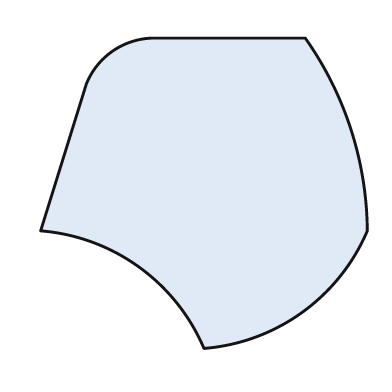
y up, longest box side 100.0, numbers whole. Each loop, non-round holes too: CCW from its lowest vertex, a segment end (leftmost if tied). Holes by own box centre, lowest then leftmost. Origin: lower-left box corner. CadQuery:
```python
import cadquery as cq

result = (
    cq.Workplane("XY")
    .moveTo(50.0, 0.0)
    .threePointArc((80.0, 11.0), (100.0, 36.0))
    .threePointArc((95.0, 67.0), (81.0, 95.0))
    .lineTo(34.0, 95.0)
    .threePointArc((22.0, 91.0), (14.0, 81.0))
    .lineTo(0.0, 36.0)
    .threePointArc((30.0, 25.0), (50.0, 0.0))
    .close()
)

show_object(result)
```